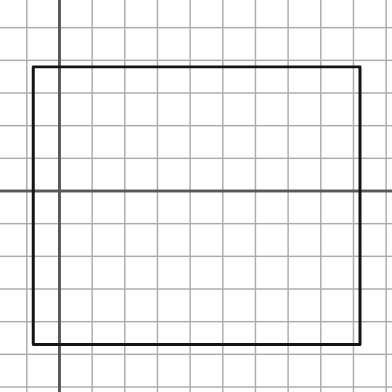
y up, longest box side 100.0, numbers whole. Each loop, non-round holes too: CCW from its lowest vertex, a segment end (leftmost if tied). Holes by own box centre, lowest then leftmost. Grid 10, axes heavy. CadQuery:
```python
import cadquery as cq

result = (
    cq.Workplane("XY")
    .moveTo(-8.0, -47.0)
    .lineTo(92.0, -47.0)
    .lineTo(92.0, 38.0)
    .lineTo(-8.0, 38.0)
    .close()
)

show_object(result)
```